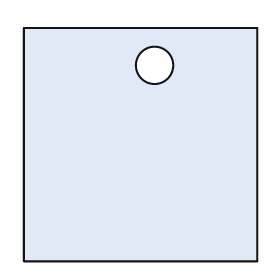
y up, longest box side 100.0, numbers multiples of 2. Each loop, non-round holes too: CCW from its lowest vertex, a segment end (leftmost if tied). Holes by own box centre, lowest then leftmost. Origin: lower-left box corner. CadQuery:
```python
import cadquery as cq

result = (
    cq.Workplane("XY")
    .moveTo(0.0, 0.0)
    .lineTo(100.0, 0.0)
    .lineTo(100.0, 100.0)
    .lineTo(0.0, 100.0)
    .close()
    .moveTo(56.0, 84.0)
    .circle(8.0)
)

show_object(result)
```